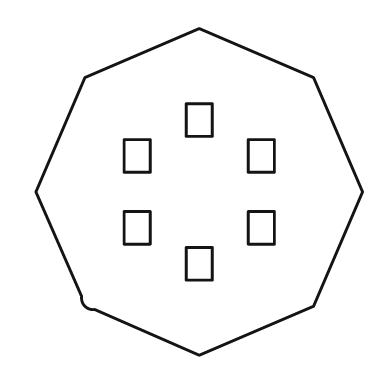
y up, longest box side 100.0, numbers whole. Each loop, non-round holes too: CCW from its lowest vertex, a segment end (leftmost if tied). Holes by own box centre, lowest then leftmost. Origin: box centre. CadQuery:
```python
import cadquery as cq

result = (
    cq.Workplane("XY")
    .moveTo(0.0, -50.0)
    .lineTo(35.0, -35.0)
    .lineTo(50.0, 0.0)
    .lineTo(35.0, 35.0)
    .lineTo(0.0, 50.0)
    .lineTo(-35.0, 35.0)
    .lineTo(-50.0, 0.0)
    .lineTo(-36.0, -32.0)
    .threePointArc((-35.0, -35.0), (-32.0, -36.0))
    .close()
    .moveTo(-4.0, -27.0)
    .lineTo(4.0, -27.0)
    .lineTo(4.0, -17.0)
    .lineTo(-4.0, -17.0)
    .close()
    .moveTo(-23.0, -16.0)
    .lineTo(-15.0, -16.0)
    .lineTo(-15.0, -6.0)
    .lineTo(-23.0, -6.0)
    .close()
    .moveTo(15.0, -16.0)
    .lineTo(23.0, -16.0)
    .lineTo(23.0, -6.0)
    .lineTo(15.0, -6.0)
    .close()
    .moveTo(-23.0, 6.0)
    .lineTo(-15.0, 6.0)
    .lineTo(-15.0, 16.0)
    .lineTo(-23.0, 16.0)
    .close()
    .moveTo(15.0, 6.0)
    .lineTo(23.0, 6.0)
    .lineTo(23.0, 16.0)
    .lineTo(15.0, 16.0)
    .close()
    .moveTo(-4.0, 17.0)
    .lineTo(4.0, 17.0)
    .lineTo(4.0, 27.0)
    .lineTo(-4.0, 27.0)
    .close()
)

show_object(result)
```